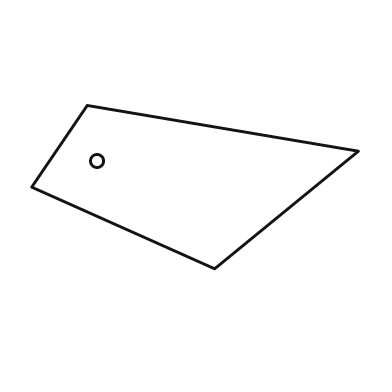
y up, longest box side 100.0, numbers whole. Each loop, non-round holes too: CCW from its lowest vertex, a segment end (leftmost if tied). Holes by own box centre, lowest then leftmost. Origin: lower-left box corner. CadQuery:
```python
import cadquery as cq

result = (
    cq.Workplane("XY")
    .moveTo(56.0, 0.0)
    .lineTo(100.0, 36.0)
    .lineTo(17.0, 50.0)
    .lineTo(0.0, 25.0)
    .close()
    .moveTo(20.0, 33.0)
    .circle(2.0)
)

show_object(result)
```